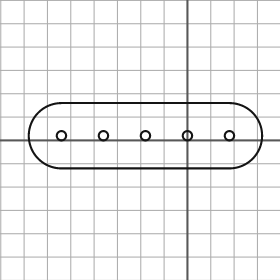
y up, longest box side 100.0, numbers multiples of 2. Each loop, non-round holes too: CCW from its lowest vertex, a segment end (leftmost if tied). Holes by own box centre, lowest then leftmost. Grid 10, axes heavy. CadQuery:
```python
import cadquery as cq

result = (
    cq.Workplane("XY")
    .moveTo(-54.0, -12.0)
    .lineTo(18.0, -12.0)
    .threePointArc((32.0, 2.0), (18.0, 16.0))
    .lineTo(-54.0, 16.0)
    .threePointArc((-68.0, 2.0), (-54.0, -12.0))
    .close()
    .moveTo(-54.0, 2.0)
    .circle(2.0)
    .moveTo(-36.0, 2.0)
    .circle(2.0)
    .moveTo(-18.0, 2.0)
    .circle(2.0)
    .moveTo(0.0, 2.0)
    .circle(2.0)
    .moveTo(18.0, 2.0)
    .circle(2.0)
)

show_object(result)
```